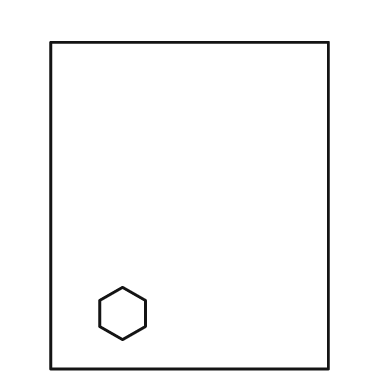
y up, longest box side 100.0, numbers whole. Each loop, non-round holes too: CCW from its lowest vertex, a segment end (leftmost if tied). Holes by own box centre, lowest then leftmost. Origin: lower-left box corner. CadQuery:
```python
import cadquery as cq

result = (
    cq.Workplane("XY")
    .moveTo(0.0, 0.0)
    .lineTo(85.0, 0.0)
    .lineTo(85.0, 100.0)
    .lineTo(0.0, 100.0)
    .close()
    .moveTo(22.0, 9.0)
    .lineTo(29.0, 13.0)
    .lineTo(29.0, 21.0)
    .lineTo(22.0, 25.0)
    .lineTo(15.0, 21.0)
    .lineTo(15.0, 13.0)
    .close()
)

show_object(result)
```